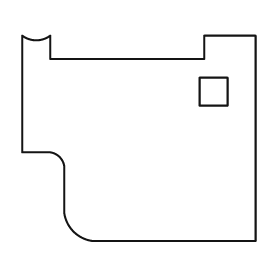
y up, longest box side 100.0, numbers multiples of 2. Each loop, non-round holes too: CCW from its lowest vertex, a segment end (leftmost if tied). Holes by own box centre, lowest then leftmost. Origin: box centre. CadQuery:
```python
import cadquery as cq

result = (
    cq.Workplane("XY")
    .moveTo(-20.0, -44.0)
    .lineTo(50.0, -44.0)
    .lineTo(50.0, 44.0)
    .lineTo(28.0, 44.0)
    .lineTo(28.0, 34.0)
    .lineTo(-38.0, 34.0)
    .lineTo(-38.0, 44.0)
    .threePointArc((-44.0, 42.0), (-50.0, 44.0))
    .lineTo(-50.0, -6.0)
    .lineTo(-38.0, -6.0)
    .threePointArc((-34.0, -8.0), (-32.0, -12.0))
    .lineTo(-32.0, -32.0)
    .threePointArc((-28.0, -40.0), (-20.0, -44.0))
    .close()
    .moveTo(26.0, 14.0)
    .lineTo(38.0, 14.0)
    .lineTo(38.0, 26.0)
    .lineTo(26.0, 26.0)
    .close()
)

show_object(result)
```